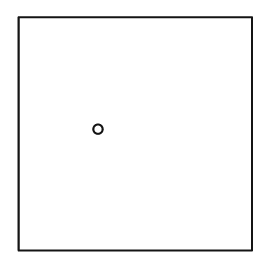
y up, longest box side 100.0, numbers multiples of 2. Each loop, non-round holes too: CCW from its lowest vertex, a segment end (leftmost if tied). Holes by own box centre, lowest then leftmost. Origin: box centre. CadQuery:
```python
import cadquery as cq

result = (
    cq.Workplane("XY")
    .moveTo(-50.0, -50.0)
    .lineTo(50.0, -50.0)
    .lineTo(50.0, 50.0)
    .lineTo(-50.0, 50.0)
    .close()
    .moveTo(-16.0, 2.0)
    .circle(2.0)
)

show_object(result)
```